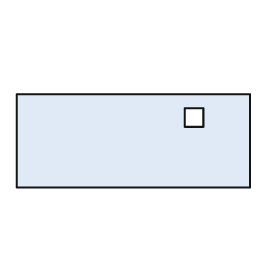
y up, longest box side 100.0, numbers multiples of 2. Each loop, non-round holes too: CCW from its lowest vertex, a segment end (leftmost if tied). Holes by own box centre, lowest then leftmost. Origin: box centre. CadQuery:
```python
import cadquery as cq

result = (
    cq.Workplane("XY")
    .moveTo(-50.0, -20.0)
    .lineTo(50.0, -20.0)
    .lineTo(50.0, 20.0)
    .lineTo(-50.0, 20.0)
    .close()
    .moveTo(22.0, 6.0)
    .lineTo(30.0, 6.0)
    .lineTo(30.0, 14.0)
    .lineTo(22.0, 14.0)
    .close()
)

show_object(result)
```